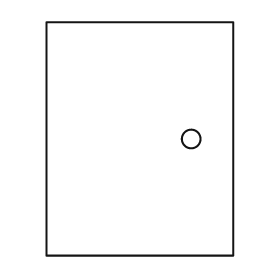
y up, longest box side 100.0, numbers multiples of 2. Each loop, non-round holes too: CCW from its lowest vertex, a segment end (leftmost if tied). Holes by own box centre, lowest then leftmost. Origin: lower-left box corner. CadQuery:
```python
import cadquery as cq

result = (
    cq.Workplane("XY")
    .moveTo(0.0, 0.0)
    .lineTo(80.0, 0.0)
    .lineTo(80.0, 100.0)
    .lineTo(0.0, 100.0)
    .close()
    .moveTo(62.0, 50.0)
    .circle(4.0)
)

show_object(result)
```